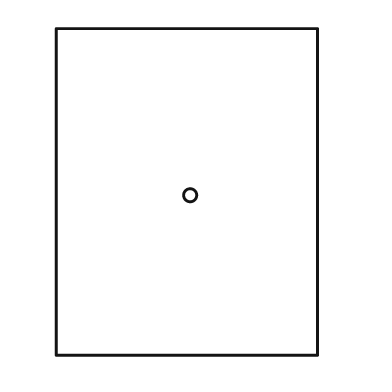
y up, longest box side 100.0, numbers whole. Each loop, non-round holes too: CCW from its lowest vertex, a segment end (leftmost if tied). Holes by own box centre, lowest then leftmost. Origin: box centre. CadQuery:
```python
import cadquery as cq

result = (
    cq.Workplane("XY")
    .moveTo(-40.0, -50.0)
    .lineTo(40.0, -50.0)
    .lineTo(40.0, 50.0)
    .lineTo(-40.0, 50.0)
    .close()
    .moveTo(1.0, -1.0)
    .circle(2.0)
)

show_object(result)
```